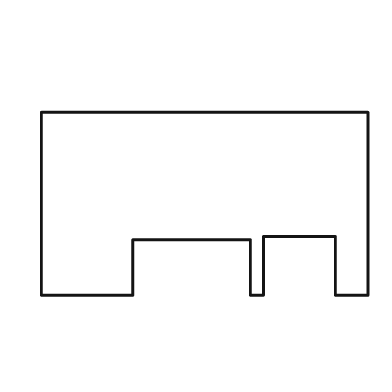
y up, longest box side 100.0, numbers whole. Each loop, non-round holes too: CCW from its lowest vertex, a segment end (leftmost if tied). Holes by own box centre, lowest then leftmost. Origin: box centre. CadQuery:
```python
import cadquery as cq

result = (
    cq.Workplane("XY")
    .moveTo(-50.0, -28.0)
    .lineTo(-22.0, -28.0)
    .lineTo(-22.0, -11.0)
    .lineTo(14.0, -11.0)
    .lineTo(14.0, -28.0)
    .lineTo(18.0, -28.0)
    .lineTo(18.0, -10.0)
    .lineTo(40.0, -10.0)
    .lineTo(40.0, -28.0)
    .lineTo(50.0, -28.0)
    .lineTo(50.0, 28.0)
    .lineTo(-50.0, 28.0)
    .close()
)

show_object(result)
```